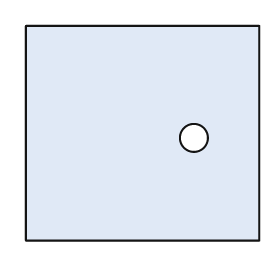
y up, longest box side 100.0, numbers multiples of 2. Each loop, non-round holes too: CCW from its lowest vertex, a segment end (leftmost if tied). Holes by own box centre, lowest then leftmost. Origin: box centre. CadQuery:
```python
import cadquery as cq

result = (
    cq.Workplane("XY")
    .moveTo(-50.0, -46.0)
    .lineTo(50.0, -46.0)
    .lineTo(50.0, 46.0)
    .lineTo(-50.0, 46.0)
    .close()
    .moveTo(22.0, -2.0)
    .circle(6.0)
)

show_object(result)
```